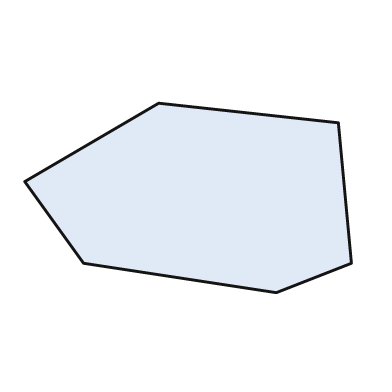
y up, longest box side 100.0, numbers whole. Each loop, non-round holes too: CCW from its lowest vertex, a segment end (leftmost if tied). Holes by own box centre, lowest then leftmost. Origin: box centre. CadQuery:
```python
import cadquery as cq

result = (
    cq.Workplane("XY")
    .moveTo(27.0, -29.0)
    .lineTo(50.0, -20.0)
    .lineTo(46.0, 23.0)
    .lineTo(-9.0, 29.0)
    .lineTo(-50.0, 5.0)
    .lineTo(-32.0, -20.0)
    .close()
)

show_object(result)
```